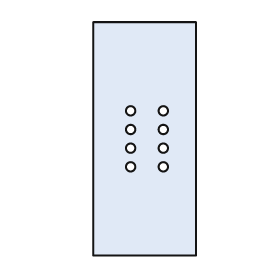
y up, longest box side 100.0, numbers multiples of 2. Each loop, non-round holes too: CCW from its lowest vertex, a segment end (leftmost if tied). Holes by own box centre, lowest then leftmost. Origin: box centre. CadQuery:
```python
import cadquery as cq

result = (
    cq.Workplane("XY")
    .moveTo(-22.0, -50.0)
    .lineTo(22.0, -50.0)
    .lineTo(22.0, 50.0)
    .lineTo(-22.0, 50.0)
    .close()
    .moveTo(-6.0, -12.0)
    .circle(2.0)
    .moveTo(8.0, -12.0)
    .circle(2.0)
    .moveTo(-6.0, -4.0)
    .circle(2.0)
    .moveTo(8.0, -4.0)
    .circle(2.0)
    .moveTo(-6.0, 4.0)
    .circle(2.0)
    .moveTo(8.0, 4.0)
    .circle(2.0)
    .moveTo(-6.0, 12.0)
    .circle(2.0)
    .moveTo(8.0, 12.0)
    .circle(2.0)
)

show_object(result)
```